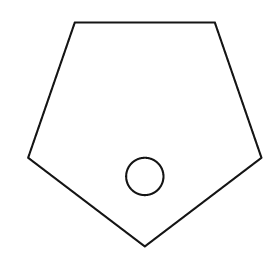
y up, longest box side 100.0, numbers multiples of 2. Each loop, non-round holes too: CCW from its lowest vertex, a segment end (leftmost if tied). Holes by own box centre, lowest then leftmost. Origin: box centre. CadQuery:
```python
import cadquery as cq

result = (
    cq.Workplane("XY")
    .moveTo(0.0, -48.0)
    .lineTo(50.0, -10.0)
    .lineTo(30.0, 48.0)
    .lineTo(-30.0, 48.0)
    .lineTo(-50.0, -10.0)
    .close()
    .moveTo(0.0, -18.0)
    .circle(8.0)
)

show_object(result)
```